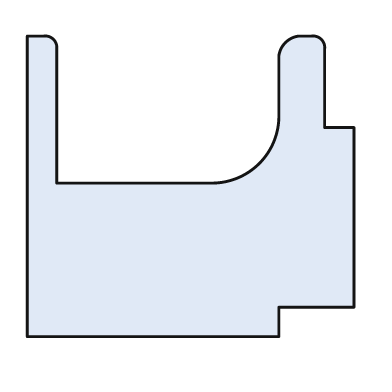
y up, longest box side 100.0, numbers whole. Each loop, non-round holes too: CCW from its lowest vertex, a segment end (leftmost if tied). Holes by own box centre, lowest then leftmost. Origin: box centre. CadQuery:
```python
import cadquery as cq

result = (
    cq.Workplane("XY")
    .moveTo(-50.0, -46.0)
    .lineTo(27.0, -46.0)
    .lineTo(27.0, -37.0)
    .lineTo(50.0, -37.0)
    .lineTo(50.0, 18.0)
    .lineTo(41.0, 18.0)
    .lineTo(41.0, 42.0)
    .threePointArc((40.0, 45.0), (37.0, 46.0))
    .lineTo(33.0, 46.0)
    .threePointArc((29.0, 44.0), (27.0, 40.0))
    .lineTo(27.0, 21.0)
    .threePointArc((21.0, 7.0), (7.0, 1.0))
    .lineTo(-41.0, 1.0)
    .lineTo(-41.0, 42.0)
    .threePointArc((-42.0, 45.0), (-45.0, 46.0))
    .lineTo(-50.0, 46.0)
    .close()
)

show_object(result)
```